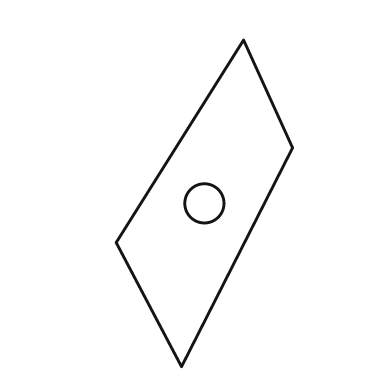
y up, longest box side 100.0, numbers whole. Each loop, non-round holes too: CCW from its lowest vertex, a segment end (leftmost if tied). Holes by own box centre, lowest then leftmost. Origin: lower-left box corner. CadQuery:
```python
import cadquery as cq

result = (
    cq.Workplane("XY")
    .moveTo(20.0, 0.0)
    .lineTo(54.0, 67.0)
    .lineTo(39.0, 100.0)
    .lineTo(0.0, 38.0)
    .close()
    .moveTo(27.0, 50.0)
    .circle(6.0)
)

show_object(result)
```